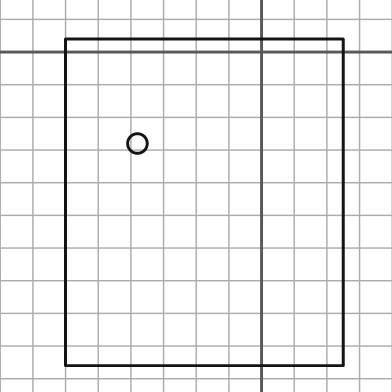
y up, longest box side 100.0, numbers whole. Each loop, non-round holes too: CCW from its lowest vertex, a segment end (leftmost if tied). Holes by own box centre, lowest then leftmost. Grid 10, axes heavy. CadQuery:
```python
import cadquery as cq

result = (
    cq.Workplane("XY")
    .moveTo(-60.0, -96.0)
    .lineTo(25.0, -96.0)
    .lineTo(25.0, 4.0)
    .lineTo(-60.0, 4.0)
    .close()
    .moveTo(-38.0, -28.0)
    .circle(3.0)
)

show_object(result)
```